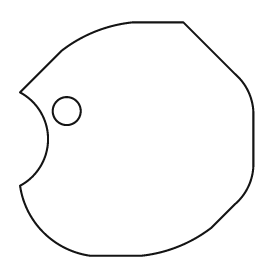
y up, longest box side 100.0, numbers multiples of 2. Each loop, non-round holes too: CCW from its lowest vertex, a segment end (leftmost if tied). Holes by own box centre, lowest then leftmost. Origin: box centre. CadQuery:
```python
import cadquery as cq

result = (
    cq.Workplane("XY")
    .moveTo(-20.0, -50.0)
    .lineTo(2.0, -50.0)
    .threePointArc((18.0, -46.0), (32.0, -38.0))
    .lineTo(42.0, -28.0)
    .threePointArc((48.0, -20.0), (50.0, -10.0))
    .lineTo(50.0, 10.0)
    .threePointArc((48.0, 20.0), (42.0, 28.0))
    .lineTo(20.0, 50.0)
    .lineTo(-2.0, 50.0)
    .threePointArc((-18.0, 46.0), (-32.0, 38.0))
    .lineTo(-50.0, 20.0)
    .threePointArc((-38.0, 0.0), (-50.0, -20.0))
    .threePointArc((-40.0, -40.0), (-20.0, -50.0))
    .close()
    .moveTo(-30.0, 12.0)
    .circle(6.0)
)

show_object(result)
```